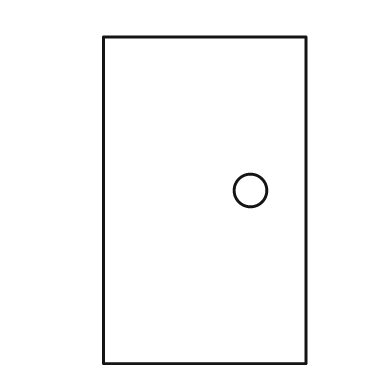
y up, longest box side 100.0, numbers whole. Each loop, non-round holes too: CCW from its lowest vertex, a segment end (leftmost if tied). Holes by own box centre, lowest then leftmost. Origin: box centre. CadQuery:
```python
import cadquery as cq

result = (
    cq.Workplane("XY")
    .moveTo(-31.0, -50.0)
    .lineTo(31.0, -50.0)
    .lineTo(31.0, 50.0)
    .lineTo(-31.0, 50.0)
    .close()
    .moveTo(14.0, 3.0)
    .circle(5.0)
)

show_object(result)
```